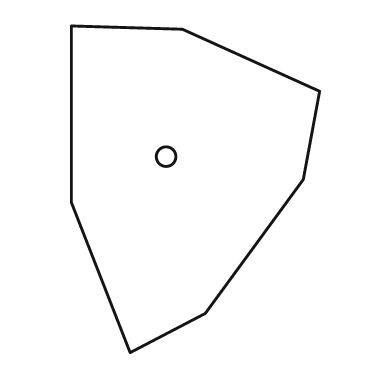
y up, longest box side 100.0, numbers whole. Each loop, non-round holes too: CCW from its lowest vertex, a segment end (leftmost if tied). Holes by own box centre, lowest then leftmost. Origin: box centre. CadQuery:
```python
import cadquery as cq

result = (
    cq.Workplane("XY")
    .moveTo(-20.0, -50.0)
    .lineTo(3.0, -38.0)
    .lineTo(33.0, 3.0)
    .lineTo(38.0, 30.0)
    .lineTo(-4.0, 49.0)
    .lineTo(-38.0, 50.0)
    .lineTo(-38.0, -4.0)
    .close()
    .moveTo(-9.0, 10.0)
    .circle(3.0)
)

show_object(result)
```